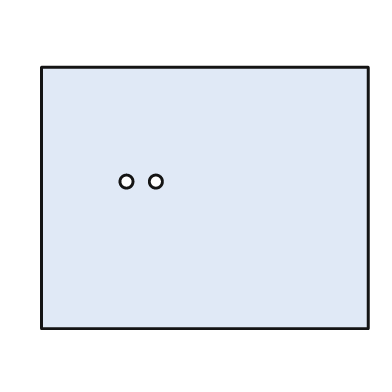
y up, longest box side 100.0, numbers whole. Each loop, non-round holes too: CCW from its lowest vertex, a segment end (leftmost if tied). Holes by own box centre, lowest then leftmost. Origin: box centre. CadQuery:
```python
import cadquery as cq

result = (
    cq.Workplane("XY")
    .moveTo(-50.0, -40.0)
    .lineTo(50.0, -40.0)
    .lineTo(50.0, 40.0)
    .lineTo(-50.0, 40.0)
    .close()
    .moveTo(-24.0, 5.0)
    .circle(2.0)
    .moveTo(-15.0, 5.0)
    .circle(2.0)
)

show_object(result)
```